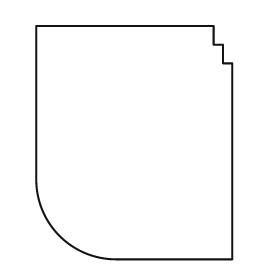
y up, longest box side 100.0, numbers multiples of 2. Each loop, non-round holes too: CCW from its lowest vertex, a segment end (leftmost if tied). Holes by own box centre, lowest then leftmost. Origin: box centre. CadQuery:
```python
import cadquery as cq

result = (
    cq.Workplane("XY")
    .moveTo(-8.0, -50.0)
    .lineTo(42.0, -50.0)
    .lineTo(42.0, 34.0)
    .lineTo(38.0, 34.0)
    .lineTo(38.0, 42.0)
    .lineTo(34.0, 42.0)
    .lineTo(34.0, 50.0)
    .lineTo(-42.0, 50.0)
    .lineTo(-42.0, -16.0)
    .threePointArc((-32.0, -40.0), (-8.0, -50.0))
    .close()
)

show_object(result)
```